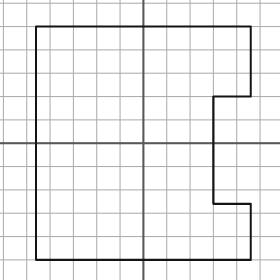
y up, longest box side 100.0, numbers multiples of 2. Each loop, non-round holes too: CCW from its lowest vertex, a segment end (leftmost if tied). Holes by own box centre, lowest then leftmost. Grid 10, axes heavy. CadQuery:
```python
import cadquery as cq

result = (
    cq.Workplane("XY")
    .moveTo(-46.0, -50.0)
    .lineTo(46.0, -50.0)
    .lineTo(46.0, -26.0)
    .lineTo(30.0, -26.0)
    .lineTo(30.0, 20.0)
    .lineTo(46.0, 20.0)
    .lineTo(46.0, 50.0)
    .lineTo(-46.0, 50.0)
    .close()
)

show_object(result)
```